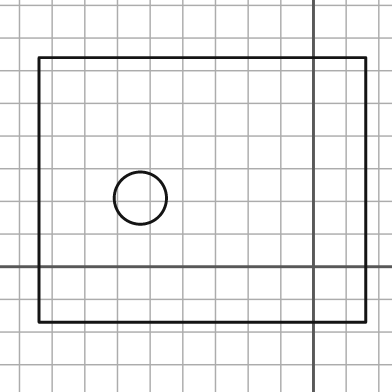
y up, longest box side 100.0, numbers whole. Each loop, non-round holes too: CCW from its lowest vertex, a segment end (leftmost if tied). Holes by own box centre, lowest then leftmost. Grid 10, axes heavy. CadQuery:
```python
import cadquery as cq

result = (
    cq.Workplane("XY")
    .moveTo(-84.0, -17.0)
    .lineTo(16.0, -17.0)
    .lineTo(16.0, 64.0)
    .lineTo(-84.0, 64.0)
    .close()
    .moveTo(-53.0, 21.0)
    .circle(8.0)
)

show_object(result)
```